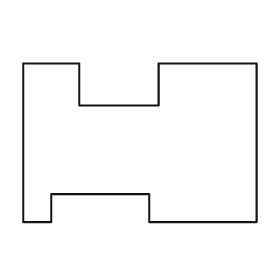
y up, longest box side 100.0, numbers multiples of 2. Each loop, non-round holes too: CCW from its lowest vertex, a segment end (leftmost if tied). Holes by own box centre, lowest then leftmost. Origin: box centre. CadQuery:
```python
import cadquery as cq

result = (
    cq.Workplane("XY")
    .moveTo(-50.0, -34.0)
    .lineTo(-38.0, -34.0)
    .lineTo(-38.0, -22.0)
    .lineTo(4.0, -22.0)
    .lineTo(4.0, -34.0)
    .lineTo(50.0, -34.0)
    .lineTo(50.0, 34.0)
    .lineTo(8.0, 34.0)
    .lineTo(8.0, 16.0)
    .lineTo(-26.0, 16.0)
    .lineTo(-26.0, 34.0)
    .lineTo(-50.0, 34.0)
    .close()
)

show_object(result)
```